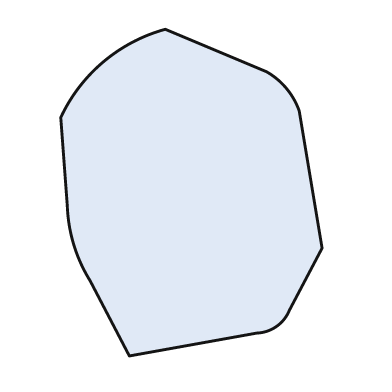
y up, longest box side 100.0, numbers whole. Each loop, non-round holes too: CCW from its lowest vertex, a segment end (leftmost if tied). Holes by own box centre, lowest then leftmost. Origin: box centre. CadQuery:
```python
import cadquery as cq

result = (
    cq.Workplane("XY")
    .moveTo(-19.0, -50.0)
    .lineTo(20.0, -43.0)
    .threePointArc((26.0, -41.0), (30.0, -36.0))
    .lineTo(40.0, -17.0)
    .lineTo(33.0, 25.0)
    .threePointArc((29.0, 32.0), (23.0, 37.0))
    .lineTo(-8.0, 50.0)
    .threePointArc((-27.0, 40.0), (-40.0, 23.0))
    .lineTo(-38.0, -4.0)
    .threePointArc((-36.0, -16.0), (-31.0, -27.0))
    .close()
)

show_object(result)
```